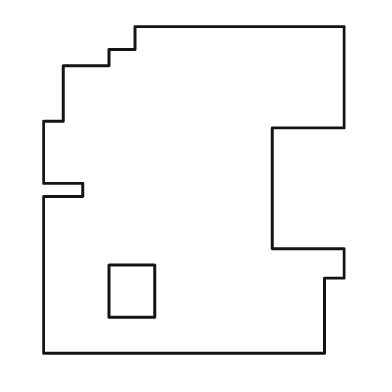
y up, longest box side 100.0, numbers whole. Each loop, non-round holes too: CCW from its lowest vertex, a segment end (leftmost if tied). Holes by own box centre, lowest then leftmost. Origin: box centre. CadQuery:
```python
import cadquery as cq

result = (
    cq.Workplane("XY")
    .moveTo(-46.0, -50.0)
    .lineTo(40.0, -50.0)
    .lineTo(40.0, -27.0)
    .lineTo(46.0, -27.0)
    .lineTo(46.0, -18.0)
    .lineTo(24.0, -18.0)
    .lineTo(24.0, 19.0)
    .lineTo(46.0, 19.0)
    .lineTo(46.0, 50.0)
    .lineTo(-18.0, 50.0)
    .lineTo(-18.0, 43.0)
    .lineTo(-26.0, 43.0)
    .lineTo(-26.0, 38.0)
    .lineTo(-40.0, 38.0)
    .lineTo(-40.0, 21.0)
    .lineTo(-46.0, 21.0)
    .lineTo(-46.0, 2.0)
    .lineTo(-34.0, 2.0)
    .lineTo(-34.0, -2.0)
    .lineTo(-46.0, -2.0)
    .close()
    .moveTo(-26.0, -39.0)
    .lineTo(-12.0, -39.0)
    .lineTo(-12.0, -23.0)
    .lineTo(-26.0, -23.0)
    .close()
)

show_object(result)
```